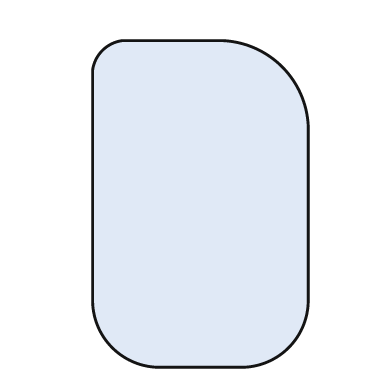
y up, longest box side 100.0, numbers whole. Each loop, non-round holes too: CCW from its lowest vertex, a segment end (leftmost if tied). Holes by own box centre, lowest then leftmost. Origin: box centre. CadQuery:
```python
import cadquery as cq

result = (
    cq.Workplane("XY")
    .moveTo(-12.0, -50.0)
    .lineTo(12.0, -50.0)
    .threePointArc((27.0, -44.0), (33.0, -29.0))
    .lineTo(33.0, 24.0)
    .threePointArc((25.0, 42.0), (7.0, 50.0))
    .lineTo(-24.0, 50.0)
    .threePointArc((-30.0, 47.0), (-33.0, 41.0))
    .lineTo(-33.0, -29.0)
    .threePointArc((-27.0, -44.0), (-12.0, -50.0))
    .close()
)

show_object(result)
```